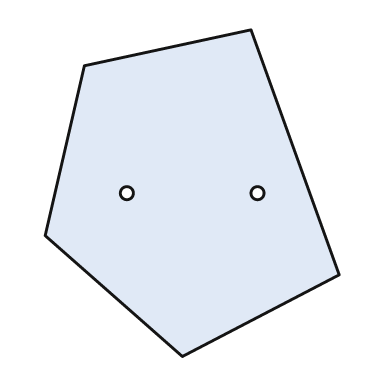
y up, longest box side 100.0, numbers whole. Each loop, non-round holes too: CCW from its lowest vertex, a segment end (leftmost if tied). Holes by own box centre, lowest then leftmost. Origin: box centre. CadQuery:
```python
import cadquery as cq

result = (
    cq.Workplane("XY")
    .moveTo(-3.0, -50.0)
    .lineTo(45.0, -25.0)
    .lineTo(18.0, 50.0)
    .lineTo(-33.0, 39.0)
    .lineTo(-45.0, -13.0)
    .close()
    .moveTo(-20.0, 0.0)
    .circle(2.0)
    .moveTo(20.0, 0.0)
    .circle(2.0)
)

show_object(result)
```